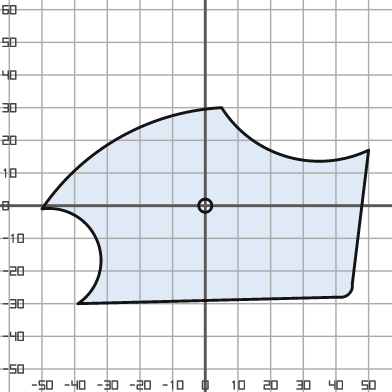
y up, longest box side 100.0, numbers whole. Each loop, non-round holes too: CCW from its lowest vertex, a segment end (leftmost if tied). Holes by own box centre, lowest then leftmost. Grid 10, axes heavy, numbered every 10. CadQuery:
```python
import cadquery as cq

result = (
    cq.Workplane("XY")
    .moveTo(-39.0, -30.0)
    .lineTo(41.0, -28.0)
    .threePointArc((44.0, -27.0), (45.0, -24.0))
    .lineTo(50.0, 17.0)
    .threePointArc((25.0, 15.0), (5.0, 30.0))
    .threePointArc((-26.0, 21.0), (-50.0, -1.0))
    .threePointArc((-33.0, -11.0), (-39.0, -30.0))
    .close()
    .moveTo(0.0, 0.0)
    .circle(2.0)
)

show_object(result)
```